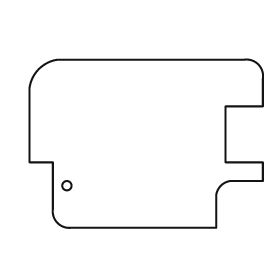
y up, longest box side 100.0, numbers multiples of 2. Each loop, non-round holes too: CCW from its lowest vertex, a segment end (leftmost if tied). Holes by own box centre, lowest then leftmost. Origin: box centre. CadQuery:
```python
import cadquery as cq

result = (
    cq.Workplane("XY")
    .moveTo(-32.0, -36.0)
    .lineTo(30.0, -36.0)
    .lineTo(30.0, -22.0)
    .threePointArc((32.0, -18.0), (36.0, -16.0))
    .lineTo(50.0, -16.0)
    .lineTo(50.0, -8.0)
    .lineTo(34.0, -8.0)
    .lineTo(34.0, 16.0)
    .lineTo(50.0, 16.0)
    .lineTo(50.0, 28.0)
    .threePointArc((48.0, 34.0), (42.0, 36.0))
    .lineTo(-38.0, 36.0)
    .threePointArc((-46.0, 32.0), (-50.0, 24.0))
    .lineTo(-50.0, -8.0)
    .lineTo(-40.0, -8.0)
    .lineTo(-40.0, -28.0)
    .threePointArc((-38.0, -34.0), (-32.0, -36.0))
    .close()
    .moveTo(-34.0, -18.0)
    .circle(2.0)
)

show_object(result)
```